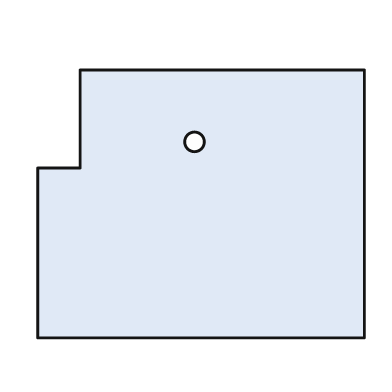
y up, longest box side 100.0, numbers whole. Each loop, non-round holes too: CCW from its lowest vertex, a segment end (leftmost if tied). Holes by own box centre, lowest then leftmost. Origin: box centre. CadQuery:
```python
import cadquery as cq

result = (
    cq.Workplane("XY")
    .moveTo(-50.0, -41.0)
    .lineTo(50.0, -41.0)
    .lineTo(50.0, 41.0)
    .lineTo(-37.0, 41.0)
    .lineTo(-37.0, 11.0)
    .lineTo(-50.0, 11.0)
    .close()
    .moveTo(-2.0, 19.0)
    .circle(3.0)
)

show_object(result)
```